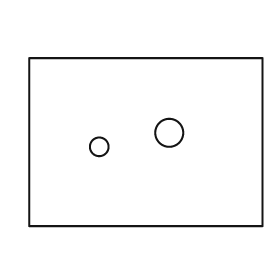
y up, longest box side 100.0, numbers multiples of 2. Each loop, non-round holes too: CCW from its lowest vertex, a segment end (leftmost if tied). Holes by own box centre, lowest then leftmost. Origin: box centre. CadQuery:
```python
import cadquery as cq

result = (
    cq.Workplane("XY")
    .moveTo(-50.0, -36.0)
    .lineTo(50.0, -36.0)
    .lineTo(50.0, 36.0)
    .lineTo(-50.0, 36.0)
    .close()
    .moveTo(-20.0, -2.0)
    .circle(4.0)
    .moveTo(10.0, 4.0)
    .circle(6.0)
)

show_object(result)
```